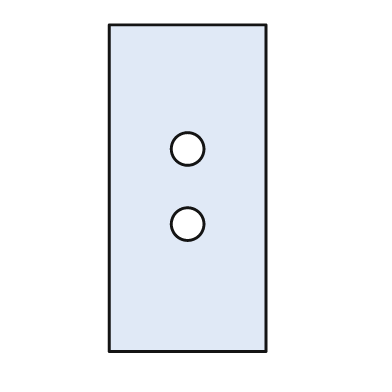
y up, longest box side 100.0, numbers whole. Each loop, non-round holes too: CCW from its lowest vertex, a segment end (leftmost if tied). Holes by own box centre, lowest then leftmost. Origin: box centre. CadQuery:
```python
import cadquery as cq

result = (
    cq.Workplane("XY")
    .moveTo(-24.0, -50.0)
    .lineTo(24.0, -50.0)
    .lineTo(24.0, 50.0)
    .lineTo(-24.0, 50.0)
    .close()
    .moveTo(0.0, -11.0)
    .circle(5.0)
    .moveTo(0.0, 12.0)
    .circle(5.0)
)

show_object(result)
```